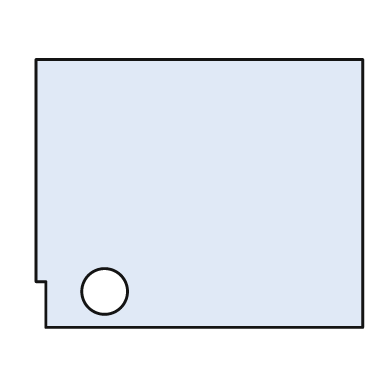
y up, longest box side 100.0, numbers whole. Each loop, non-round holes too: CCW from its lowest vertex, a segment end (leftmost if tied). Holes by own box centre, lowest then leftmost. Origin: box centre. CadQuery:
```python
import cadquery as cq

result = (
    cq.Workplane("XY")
    .moveTo(-47.0, -41.0)
    .lineTo(50.0, -41.0)
    .lineTo(50.0, 41.0)
    .lineTo(-50.0, 41.0)
    .lineTo(-50.0, -27.0)
    .lineTo(-47.0, -27.0)
    .close()
    .moveTo(-29.0, -30.0)
    .circle(7.0)
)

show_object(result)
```